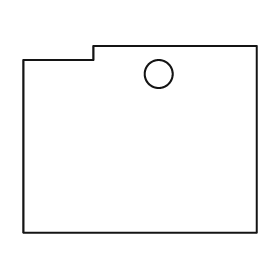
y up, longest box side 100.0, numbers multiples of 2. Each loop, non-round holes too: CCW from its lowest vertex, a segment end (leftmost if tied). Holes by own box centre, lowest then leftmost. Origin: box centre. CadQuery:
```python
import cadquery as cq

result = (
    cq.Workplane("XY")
    .moveTo(-50.0, -40.0)
    .lineTo(50.0, -40.0)
    .lineTo(50.0, 40.0)
    .lineTo(-20.0, 40.0)
    .lineTo(-20.0, 34.0)
    .lineTo(-50.0, 34.0)
    .close()
    .moveTo(8.0, 28.0)
    .circle(6.0)
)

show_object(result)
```